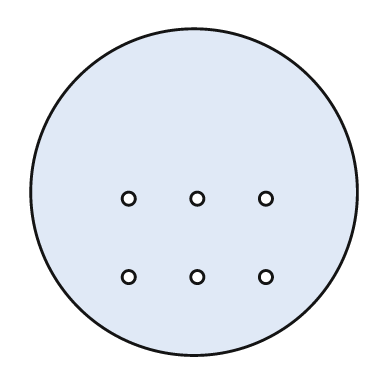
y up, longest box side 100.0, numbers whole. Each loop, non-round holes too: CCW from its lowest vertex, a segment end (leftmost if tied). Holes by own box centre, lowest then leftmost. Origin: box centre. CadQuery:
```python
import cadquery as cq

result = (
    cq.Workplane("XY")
    .moveTo(0.0, 0.0)
    .circle(50.0)
    .moveTo(-20.0, -26.0)
    .circle(2.0)
    .moveTo(1.0, -26.0)
    .circle(2.0)
    .moveTo(22.0, -26.0)
    .circle(2.0)
    .moveTo(-20.0, -2.0)
    .circle(2.0)
    .moveTo(1.0, -2.0)
    .circle(2.0)
    .moveTo(22.0, -2.0)
    .circle(2.0)
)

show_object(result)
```